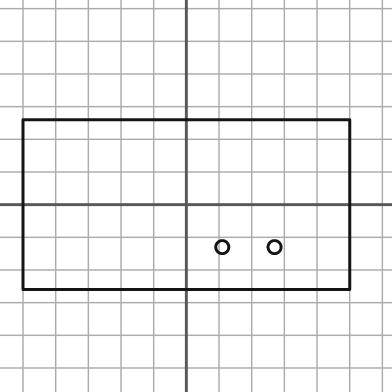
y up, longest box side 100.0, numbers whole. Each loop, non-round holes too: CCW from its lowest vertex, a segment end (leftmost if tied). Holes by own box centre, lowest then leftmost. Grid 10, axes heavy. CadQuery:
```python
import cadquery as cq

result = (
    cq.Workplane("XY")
    .moveTo(-50.0, -26.0)
    .lineTo(50.0, -26.0)
    .lineTo(50.0, 26.0)
    .lineTo(-50.0, 26.0)
    .close()
    .moveTo(11.0, -13.0)
    .circle(2.0)
    .moveTo(27.0, -13.0)
    .circle(2.0)
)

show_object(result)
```